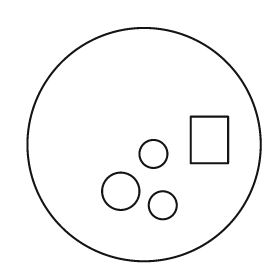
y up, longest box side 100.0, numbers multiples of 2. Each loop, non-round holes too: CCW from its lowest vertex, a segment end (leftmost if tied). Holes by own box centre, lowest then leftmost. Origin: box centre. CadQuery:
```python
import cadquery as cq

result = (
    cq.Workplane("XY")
    .moveTo(0.0, 0.0)
    .circle(50.0)
    .moveTo(8.0, -26.0)
    .circle(6.0)
    .moveTo(-10.0, -20.0)
    .circle(8.0)
    .moveTo(4.0, -4.0)
    .circle(6.0)
    .moveTo(20.0, -8.0)
    .lineTo(36.0, -8.0)
    .lineTo(36.0, 12.0)
    .lineTo(20.0, 12.0)
    .close()
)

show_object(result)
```